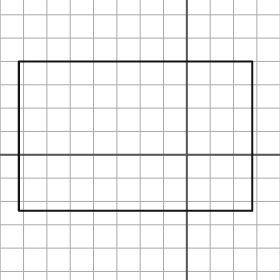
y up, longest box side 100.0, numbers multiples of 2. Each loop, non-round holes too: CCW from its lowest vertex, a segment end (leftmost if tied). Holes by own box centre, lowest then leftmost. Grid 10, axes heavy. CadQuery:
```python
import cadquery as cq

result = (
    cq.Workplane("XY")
    .moveTo(-72.0, -24.0)
    .lineTo(28.0, -24.0)
    .lineTo(28.0, 40.0)
    .lineTo(-72.0, 40.0)
    .close()
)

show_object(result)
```